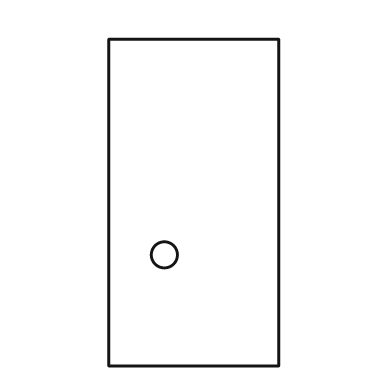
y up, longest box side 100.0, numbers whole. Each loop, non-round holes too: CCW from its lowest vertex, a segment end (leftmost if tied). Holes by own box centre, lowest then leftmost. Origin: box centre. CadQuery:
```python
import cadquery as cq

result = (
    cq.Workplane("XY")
    .moveTo(-26.0, -50.0)
    .lineTo(26.0, -50.0)
    .lineTo(26.0, 50.0)
    .lineTo(-26.0, 50.0)
    .close()
    .moveTo(-9.0, -16.0)
    .circle(4.0)
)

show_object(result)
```